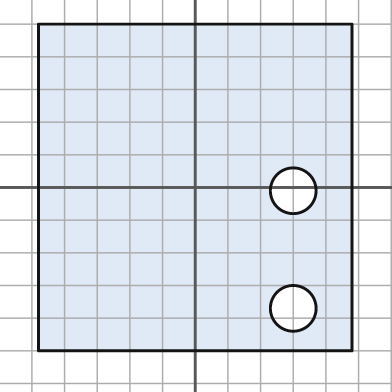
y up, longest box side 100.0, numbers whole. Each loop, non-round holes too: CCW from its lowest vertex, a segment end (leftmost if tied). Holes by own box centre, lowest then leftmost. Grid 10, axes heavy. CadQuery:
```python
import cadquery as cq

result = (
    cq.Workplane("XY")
    .moveTo(-48.0, -50.0)
    .lineTo(48.0, -50.0)
    .lineTo(48.0, 50.0)
    .lineTo(-48.0, 50.0)
    .close()
    .moveTo(30.0, -37.0)
    .circle(7.0)
    .moveTo(30.0, -1.0)
    .circle(7.0)
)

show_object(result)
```